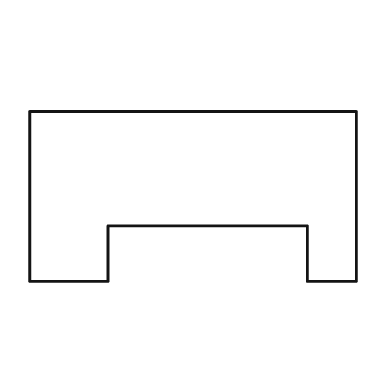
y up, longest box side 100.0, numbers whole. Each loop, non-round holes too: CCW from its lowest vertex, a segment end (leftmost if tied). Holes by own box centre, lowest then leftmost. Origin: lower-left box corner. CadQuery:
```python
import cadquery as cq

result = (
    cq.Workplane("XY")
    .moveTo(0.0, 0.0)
    .lineTo(24.0, 0.0)
    .lineTo(24.0, 17.0)
    .lineTo(85.0, 17.0)
    .lineTo(85.0, 0.0)
    .lineTo(100.0, 0.0)
    .lineTo(100.0, 52.0)
    .lineTo(0.0, 52.0)
    .close()
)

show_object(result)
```